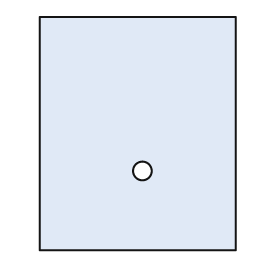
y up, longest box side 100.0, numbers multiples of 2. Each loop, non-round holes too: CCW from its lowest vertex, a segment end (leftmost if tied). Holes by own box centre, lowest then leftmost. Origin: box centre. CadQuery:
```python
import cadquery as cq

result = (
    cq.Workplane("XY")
    .moveTo(-42.0, -50.0)
    .lineTo(42.0, -50.0)
    .lineTo(42.0, 50.0)
    .lineTo(-42.0, 50.0)
    .close()
    .moveTo(2.0, -16.0)
    .circle(4.0)
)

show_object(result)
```